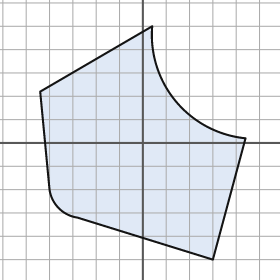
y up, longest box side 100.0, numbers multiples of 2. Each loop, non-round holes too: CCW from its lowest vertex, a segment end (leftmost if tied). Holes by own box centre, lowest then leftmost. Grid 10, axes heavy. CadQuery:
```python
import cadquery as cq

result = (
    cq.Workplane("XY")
    .moveTo(30.0, -50.0)
    .lineTo(44.0, 2.0)
    .threePointArc((14.0, 18.0), (4.0, 50.0))
    .lineTo(-44.0, 22.0)
    .lineTo(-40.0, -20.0)
    .threePointArc((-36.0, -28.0), (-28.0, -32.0))
    .close()
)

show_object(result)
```